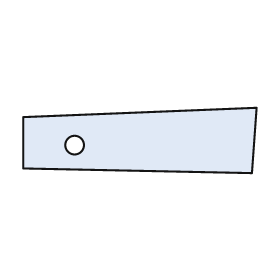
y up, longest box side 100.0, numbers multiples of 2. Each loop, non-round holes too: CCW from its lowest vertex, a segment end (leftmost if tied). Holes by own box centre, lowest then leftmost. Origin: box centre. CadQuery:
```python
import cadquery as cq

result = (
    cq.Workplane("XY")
    .moveTo(48.0, -14.0)
    .lineTo(50.0, 14.0)
    .lineTo(-50.0, 10.0)
    .lineTo(-50.0, -12.0)
    .close()
    .moveTo(-28.0, -2.0)
    .circle(4.0)
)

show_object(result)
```